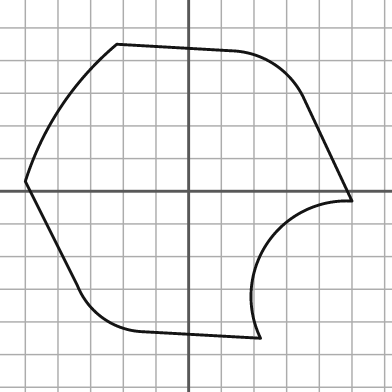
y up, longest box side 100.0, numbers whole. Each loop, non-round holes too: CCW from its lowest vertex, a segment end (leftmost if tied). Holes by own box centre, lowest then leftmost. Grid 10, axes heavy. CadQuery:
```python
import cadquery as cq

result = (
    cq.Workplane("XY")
    .moveTo(22.0, -45.0)
    .threePointArc((24.0, -16.0), (50.0, -3.0))
    .lineTo(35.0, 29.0)
    .threePointArc((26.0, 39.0), (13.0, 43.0))
    .lineTo(-22.0, 45.0)
    .threePointArc((-39.0, 26.0), (-50.0, 3.0))
    .lineTo(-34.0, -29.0)
    .threePointArc((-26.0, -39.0), (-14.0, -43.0))
    .close()
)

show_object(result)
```